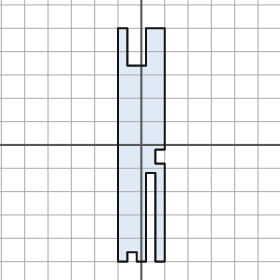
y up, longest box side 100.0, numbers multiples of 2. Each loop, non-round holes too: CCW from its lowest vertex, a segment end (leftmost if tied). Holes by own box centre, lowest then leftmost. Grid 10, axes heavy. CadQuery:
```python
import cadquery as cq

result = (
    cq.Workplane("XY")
    .moveTo(-10.0, -50.0)
    .lineTo(-6.0, -50.0)
    .lineTo(-6.0, -46.0)
    .lineTo(-2.0, -46.0)
    .lineTo(-2.0, -50.0)
    .lineTo(2.0, -50.0)
    .lineTo(2.0, -12.0)
    .lineTo(6.0, -12.0)
    .lineTo(6.0, -50.0)
    .lineTo(10.0, -50.0)
    .lineTo(10.0, -8.0)
    .lineTo(6.0, -8.0)
    .lineTo(6.0, -2.0)
    .lineTo(10.0, -2.0)
    .lineTo(10.0, 50.0)
    .lineTo(2.0, 50.0)
    .lineTo(2.0, 34.0)
    .lineTo(-6.0, 34.0)
    .lineTo(-6.0, 50.0)
    .lineTo(-10.0, 50.0)
    .close()
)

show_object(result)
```